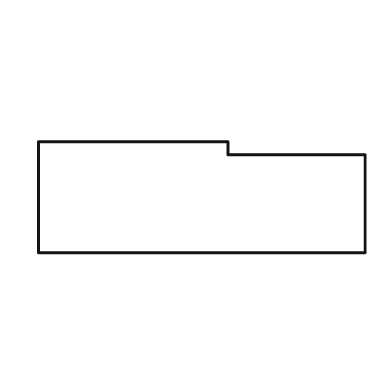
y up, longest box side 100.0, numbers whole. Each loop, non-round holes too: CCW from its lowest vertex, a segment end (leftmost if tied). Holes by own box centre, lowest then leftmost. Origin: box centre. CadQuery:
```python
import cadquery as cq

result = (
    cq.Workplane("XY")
    .moveTo(-50.0, -17.0)
    .lineTo(50.0, -17.0)
    .lineTo(50.0, 13.0)
    .lineTo(8.0, 13.0)
    .lineTo(8.0, 17.0)
    .lineTo(-50.0, 17.0)
    .close()
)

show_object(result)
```